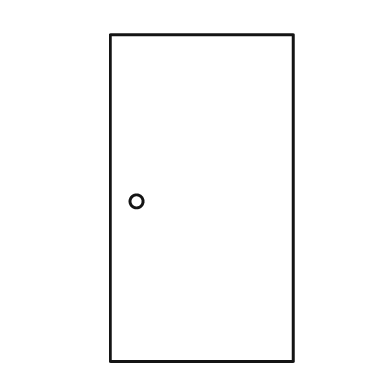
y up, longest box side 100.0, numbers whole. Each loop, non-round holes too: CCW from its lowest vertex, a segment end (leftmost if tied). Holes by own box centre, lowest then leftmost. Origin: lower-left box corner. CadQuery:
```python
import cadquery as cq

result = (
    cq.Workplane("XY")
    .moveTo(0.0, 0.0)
    .lineTo(56.0, 0.0)
    .lineTo(56.0, 100.0)
    .lineTo(0.0, 100.0)
    .close()
    .moveTo(8.0, 49.0)
    .circle(2.0)
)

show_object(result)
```